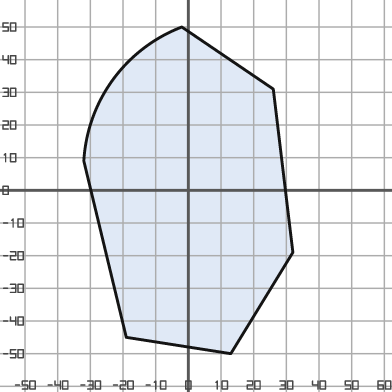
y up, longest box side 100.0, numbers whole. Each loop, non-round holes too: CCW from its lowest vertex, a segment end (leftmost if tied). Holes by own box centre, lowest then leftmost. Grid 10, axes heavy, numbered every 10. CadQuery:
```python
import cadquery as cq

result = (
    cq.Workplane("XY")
    .moveTo(13.0, -50.0)
    .lineTo(32.0, -19.0)
    .lineTo(26.0, 31.0)
    .lineTo(-2.0, 50.0)
    .threePointArc((-23.0, 34.0), (-32.0, 9.0))
    .lineTo(-19.0, -45.0)
    .close()
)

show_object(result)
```